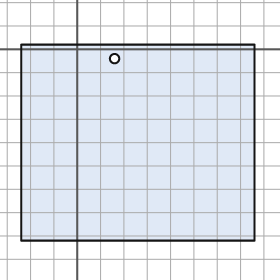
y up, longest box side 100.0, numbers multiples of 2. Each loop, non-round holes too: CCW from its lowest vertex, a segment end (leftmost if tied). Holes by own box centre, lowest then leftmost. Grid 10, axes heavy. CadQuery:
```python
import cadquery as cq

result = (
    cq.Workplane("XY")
    .moveTo(-24.0, -82.0)
    .lineTo(76.0, -82.0)
    .lineTo(76.0, 2.0)
    .lineTo(-24.0, 2.0)
    .close()
    .moveTo(16.0, -4.0)
    .circle(2.0)
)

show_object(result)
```